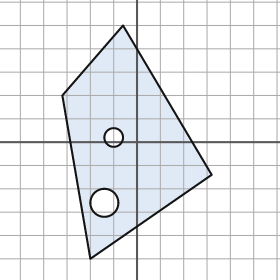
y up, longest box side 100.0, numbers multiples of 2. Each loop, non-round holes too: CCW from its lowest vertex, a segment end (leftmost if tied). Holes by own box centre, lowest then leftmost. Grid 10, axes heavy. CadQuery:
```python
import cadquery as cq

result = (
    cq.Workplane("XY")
    .moveTo(-20.0, -50.0)
    .lineTo(32.0, -14.0)
    .lineTo(-6.0, 50.0)
    .lineTo(-32.0, 20.0)
    .close()
    .moveTo(-14.0, -26.0)
    .circle(6.0)
    .moveTo(-10.0, 2.0)
    .circle(4.0)
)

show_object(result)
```